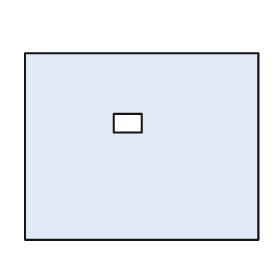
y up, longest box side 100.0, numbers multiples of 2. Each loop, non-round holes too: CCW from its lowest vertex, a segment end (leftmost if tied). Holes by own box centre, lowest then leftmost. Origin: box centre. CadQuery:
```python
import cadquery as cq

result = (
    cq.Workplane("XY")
    .moveTo(-50.0, -40.0)
    .lineTo(50.0, -40.0)
    .lineTo(50.0, 40.0)
    .lineTo(-50.0, 40.0)
    .close()
    .moveTo(-12.0, 6.0)
    .lineTo(0.0, 6.0)
    .lineTo(0.0, 14.0)
    .lineTo(-12.0, 14.0)
    .close()
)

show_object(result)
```